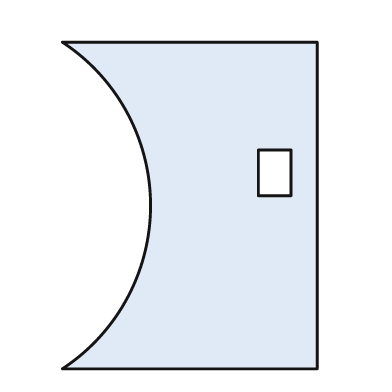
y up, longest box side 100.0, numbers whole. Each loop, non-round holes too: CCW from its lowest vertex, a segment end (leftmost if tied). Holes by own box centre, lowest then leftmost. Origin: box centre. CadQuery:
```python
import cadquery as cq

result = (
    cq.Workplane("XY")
    .moveTo(-39.0, -50.0)
    .lineTo(39.0, -50.0)
    .lineTo(39.0, 50.0)
    .lineTo(-39.0, 50.0)
    .threePointArc((-12.0, 0.0), (-39.0, -50.0))
    .close()
    .moveTo(21.0, 3.0)
    .lineTo(31.0, 3.0)
    .lineTo(31.0, 17.0)
    .lineTo(21.0, 17.0)
    .close()
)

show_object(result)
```